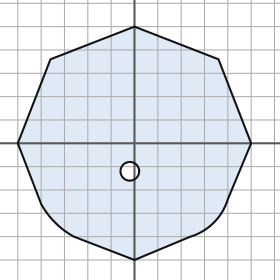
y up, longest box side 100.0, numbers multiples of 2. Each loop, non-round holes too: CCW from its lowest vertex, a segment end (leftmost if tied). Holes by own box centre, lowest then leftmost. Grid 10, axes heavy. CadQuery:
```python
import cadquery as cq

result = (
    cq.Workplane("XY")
    .moveTo(0.0, -50.0)
    .lineTo(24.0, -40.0)
    .threePointArc((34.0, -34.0), (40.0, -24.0))
    .lineTo(50.0, 0.0)
    .lineTo(36.0, 36.0)
    .lineTo(0.0, 50.0)
    .lineTo(-36.0, 36.0)
    .lineTo(-50.0, 0.0)
    .lineTo(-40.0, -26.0)
    .threePointArc((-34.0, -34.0), (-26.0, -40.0))
    .close()
    .moveTo(-2.0, -12.0)
    .circle(4.0)
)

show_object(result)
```